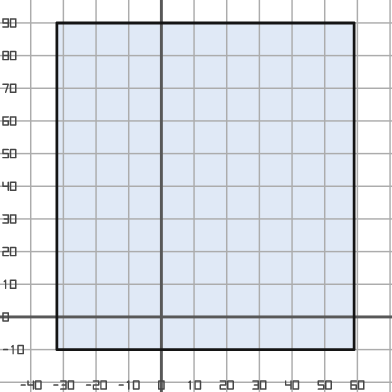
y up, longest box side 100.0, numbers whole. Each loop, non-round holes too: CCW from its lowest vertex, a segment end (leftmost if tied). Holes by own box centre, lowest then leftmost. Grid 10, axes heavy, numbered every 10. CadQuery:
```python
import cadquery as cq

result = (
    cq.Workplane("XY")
    .moveTo(-32.0, -10.0)
    .lineTo(59.0, -10.0)
    .lineTo(59.0, 90.0)
    .lineTo(-32.0, 90.0)
    .close()
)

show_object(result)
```